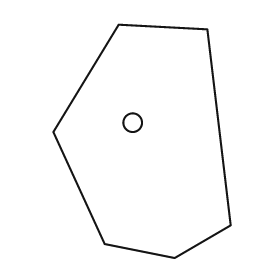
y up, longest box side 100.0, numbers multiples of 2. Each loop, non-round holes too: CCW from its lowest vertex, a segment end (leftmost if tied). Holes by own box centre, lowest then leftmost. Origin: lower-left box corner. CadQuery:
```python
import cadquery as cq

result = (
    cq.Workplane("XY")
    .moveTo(52.0, 0.0)
    .lineTo(76.0, 14.0)
    .lineTo(66.0, 98.0)
    .lineTo(28.0, 100.0)
    .lineTo(0.0, 54.0)
    .lineTo(22.0, 6.0)
    .close()
    .moveTo(34.0, 58.0)
    .circle(4.0)
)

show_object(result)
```